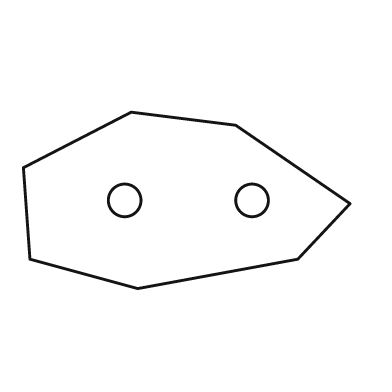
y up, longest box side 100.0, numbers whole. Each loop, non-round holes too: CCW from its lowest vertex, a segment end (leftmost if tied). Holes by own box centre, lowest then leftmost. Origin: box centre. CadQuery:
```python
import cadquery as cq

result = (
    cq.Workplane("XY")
    .moveTo(-15.0, -27.0)
    .lineTo(34.0, -18.0)
    .lineTo(50.0, -1.0)
    .lineTo(15.0, 23.0)
    .lineTo(-17.0, 27.0)
    .lineTo(-50.0, 10.0)
    .lineTo(-48.0, -18.0)
    .close()
    .moveTo(-19.0, 0.0)
    .circle(5.0)
    .moveTo(20.0, 0.0)
    .circle(5.0)
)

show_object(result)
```